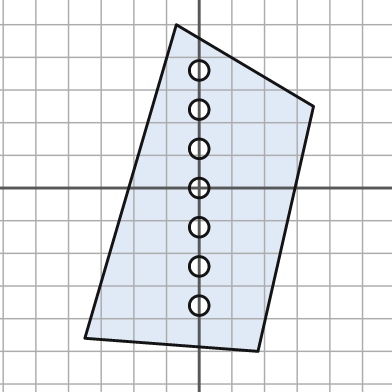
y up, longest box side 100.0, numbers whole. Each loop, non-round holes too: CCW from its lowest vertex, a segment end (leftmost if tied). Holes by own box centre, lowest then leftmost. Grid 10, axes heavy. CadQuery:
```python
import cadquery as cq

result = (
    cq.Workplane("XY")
    .moveTo(18.0, -50.0)
    .lineTo(35.0, 25.0)
    .lineTo(-7.0, 50.0)
    .lineTo(-35.0, -46.0)
    .close()
    .moveTo(0.0, -36.0)
    .circle(3.0)
    .moveTo(0.0, -24.0)
    .circle(3.0)
    .moveTo(0.0, -12.0)
    .circle(3.0)
    .moveTo(0.0, 0.0)
    .circle(3.0)
    .moveTo(0.0, 12.0)
    .circle(3.0)
    .moveTo(0.0, 24.0)
    .circle(3.0)
    .moveTo(0.0, 36.0)
    .circle(3.0)
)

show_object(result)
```